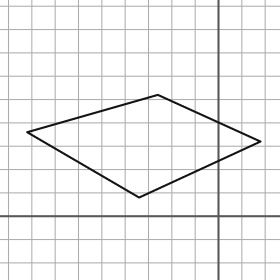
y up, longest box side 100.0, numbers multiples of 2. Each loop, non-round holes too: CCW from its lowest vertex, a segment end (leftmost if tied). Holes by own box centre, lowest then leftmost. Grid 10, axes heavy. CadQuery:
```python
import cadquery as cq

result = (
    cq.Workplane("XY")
    .moveTo(-34.0, 8.0)
    .lineTo(18.0, 32.0)
    .lineTo(-26.0, 52.0)
    .lineTo(-82.0, 36.0)
    .close()
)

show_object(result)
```